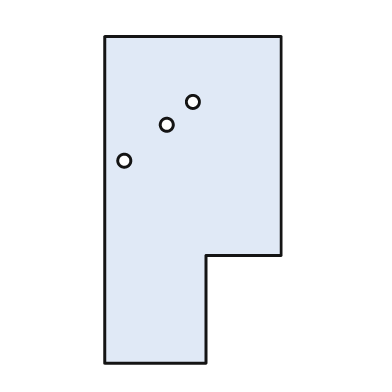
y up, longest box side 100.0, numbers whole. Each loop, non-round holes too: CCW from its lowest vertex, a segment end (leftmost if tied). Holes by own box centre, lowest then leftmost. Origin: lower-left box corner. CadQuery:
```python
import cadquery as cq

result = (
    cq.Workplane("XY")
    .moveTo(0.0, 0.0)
    .lineTo(31.0, 0.0)
    .lineTo(31.0, 33.0)
    .lineTo(54.0, 33.0)
    .lineTo(54.0, 100.0)
    .lineTo(0.0, 100.0)
    .close()
    .moveTo(6.0, 62.0)
    .circle(2.0)
    .moveTo(19.0, 73.0)
    .circle(2.0)
    .moveTo(27.0, 80.0)
    .circle(2.0)
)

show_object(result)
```